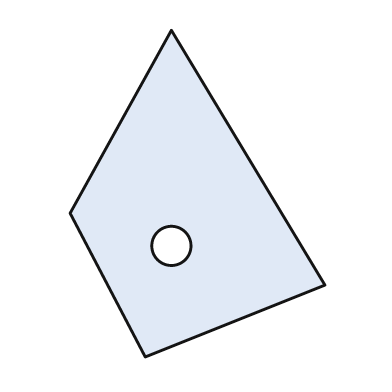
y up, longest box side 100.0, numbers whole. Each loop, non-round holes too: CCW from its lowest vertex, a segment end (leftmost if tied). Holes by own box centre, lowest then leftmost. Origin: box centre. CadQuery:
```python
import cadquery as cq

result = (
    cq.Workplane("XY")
    .moveTo(-16.0, -50.0)
    .lineTo(39.0, -28.0)
    .lineTo(-8.0, 50.0)
    .lineTo(-39.0, -6.0)
    .close()
    .moveTo(-8.0, -16.0)
    .circle(6.0)
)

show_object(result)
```